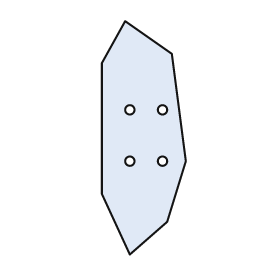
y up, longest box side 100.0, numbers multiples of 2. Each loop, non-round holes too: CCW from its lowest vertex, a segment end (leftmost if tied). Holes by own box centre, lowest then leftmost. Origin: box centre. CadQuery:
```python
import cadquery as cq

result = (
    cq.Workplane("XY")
    .moveTo(-6.0, -50.0)
    .lineTo(10.0, -36.0)
    .lineTo(18.0, -10.0)
    .lineTo(12.0, 36.0)
    .lineTo(-8.0, 50.0)
    .lineTo(-18.0, 32.0)
    .lineTo(-18.0, -24.0)
    .close()
    .moveTo(-6.0, -10.0)
    .circle(2.0)
    .moveTo(8.0, -10.0)
    .circle(2.0)
    .moveTo(-6.0, 12.0)
    .circle(2.0)
    .moveTo(8.0, 12.0)
    .circle(2.0)
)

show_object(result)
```